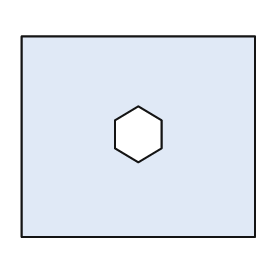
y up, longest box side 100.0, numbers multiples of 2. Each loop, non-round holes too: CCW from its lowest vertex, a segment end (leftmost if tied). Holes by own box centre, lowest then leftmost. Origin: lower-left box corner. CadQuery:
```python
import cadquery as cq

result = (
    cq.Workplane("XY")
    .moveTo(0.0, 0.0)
    .lineTo(100.0, 0.0)
    .lineTo(100.0, 86.0)
    .lineTo(0.0, 86.0)
    .close()
    .moveTo(50.0, 32.0)
    .lineTo(60.0, 38.0)
    .lineTo(60.0, 50.0)
    .lineTo(50.0, 56.0)
    .lineTo(40.0, 50.0)
    .lineTo(40.0, 38.0)
    .close()
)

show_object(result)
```